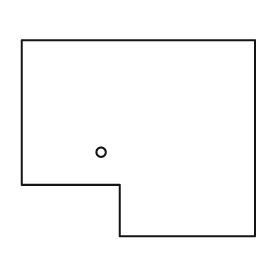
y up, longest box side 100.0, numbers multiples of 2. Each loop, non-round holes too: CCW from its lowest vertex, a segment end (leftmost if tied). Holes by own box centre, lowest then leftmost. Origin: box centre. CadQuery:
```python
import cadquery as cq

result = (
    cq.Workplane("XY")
    .moveTo(-8.0, -42.0)
    .lineTo(50.0, -42.0)
    .lineTo(50.0, 42.0)
    .lineTo(-50.0, 42.0)
    .lineTo(-50.0, -20.0)
    .lineTo(-8.0, -20.0)
    .close()
    .moveTo(-16.0, -6.0)
    .circle(2.0)
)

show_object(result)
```